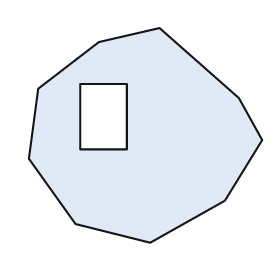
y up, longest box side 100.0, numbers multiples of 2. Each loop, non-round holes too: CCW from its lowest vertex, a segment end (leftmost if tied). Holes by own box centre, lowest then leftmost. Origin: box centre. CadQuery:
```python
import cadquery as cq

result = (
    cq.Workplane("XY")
    .moveTo(2.0, -46.0)
    .lineTo(34.0, -28.0)
    .lineTo(50.0, -2.0)
    .lineTo(40.0, 16.0)
    .lineTo(6.0, 46.0)
    .lineTo(-20.0, 40.0)
    .lineTo(-46.0, 20.0)
    .lineTo(-50.0, -10.0)
    .lineTo(-30.0, -38.0)
    .close()
    .moveTo(-28.0, -6.0)
    .lineTo(-8.0, -6.0)
    .lineTo(-8.0, 22.0)
    .lineTo(-28.0, 22.0)
    .close()
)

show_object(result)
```